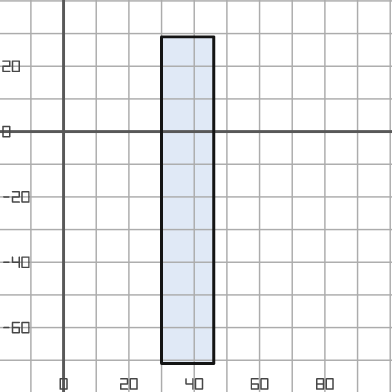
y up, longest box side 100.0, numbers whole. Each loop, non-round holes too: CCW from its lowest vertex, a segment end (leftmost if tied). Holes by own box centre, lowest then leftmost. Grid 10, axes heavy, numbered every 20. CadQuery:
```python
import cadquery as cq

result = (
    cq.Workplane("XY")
    .moveTo(30.0, -71.0)
    .lineTo(46.0, -71.0)
    .lineTo(46.0, 29.0)
    .lineTo(30.0, 29.0)
    .close()
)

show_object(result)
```